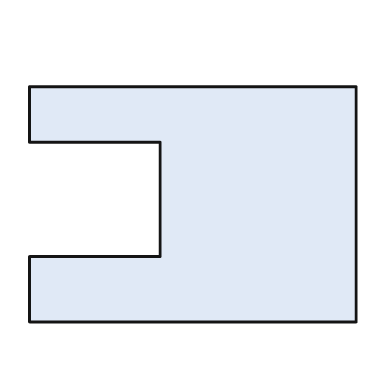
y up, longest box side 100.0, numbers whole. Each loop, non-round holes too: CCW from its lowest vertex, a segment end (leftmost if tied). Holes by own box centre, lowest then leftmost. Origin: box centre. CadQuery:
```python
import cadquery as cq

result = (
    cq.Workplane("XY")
    .moveTo(-50.0, -36.0)
    .lineTo(50.0, -36.0)
    .lineTo(50.0, 36.0)
    .lineTo(-50.0, 36.0)
    .lineTo(-50.0, 19.0)
    .lineTo(-10.0, 19.0)
    .lineTo(-10.0, -16.0)
    .lineTo(-50.0, -16.0)
    .close()
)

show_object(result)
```